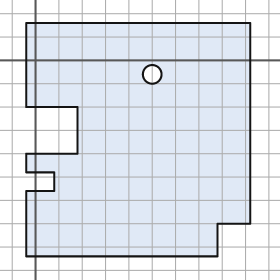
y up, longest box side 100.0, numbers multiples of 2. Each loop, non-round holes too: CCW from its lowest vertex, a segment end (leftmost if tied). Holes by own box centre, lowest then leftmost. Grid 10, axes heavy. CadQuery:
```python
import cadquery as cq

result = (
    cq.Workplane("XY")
    .moveTo(-4.0, -84.0)
    .lineTo(78.0, -84.0)
    .lineTo(78.0, -70.0)
    .lineTo(92.0, -70.0)
    .lineTo(92.0, 16.0)
    .lineTo(-4.0, 16.0)
    .lineTo(-4.0, -20.0)
    .lineTo(18.0, -20.0)
    .lineTo(18.0, -40.0)
    .lineTo(-4.0, -40.0)
    .lineTo(-4.0, -48.0)
    .lineTo(8.0, -48.0)
    .lineTo(8.0, -56.0)
    .lineTo(-4.0, -56.0)
    .close()
    .moveTo(50.0, -6.0)
    .circle(4.0)
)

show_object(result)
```